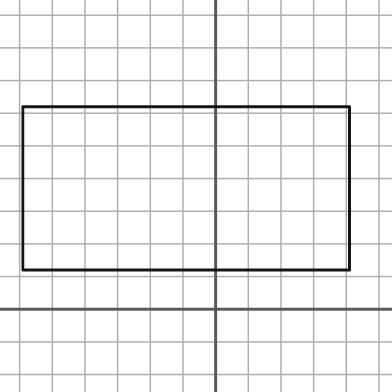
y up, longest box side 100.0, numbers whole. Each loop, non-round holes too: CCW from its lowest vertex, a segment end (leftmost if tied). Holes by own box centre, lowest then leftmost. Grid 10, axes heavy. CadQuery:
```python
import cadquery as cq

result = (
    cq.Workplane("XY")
    .moveTo(-59.0, 12.0)
    .lineTo(41.0, 12.0)
    .lineTo(41.0, 62.0)
    .lineTo(-59.0, 62.0)
    .close()
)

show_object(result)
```